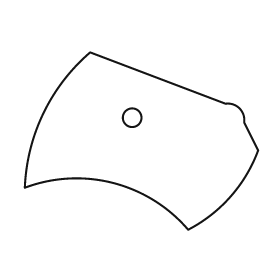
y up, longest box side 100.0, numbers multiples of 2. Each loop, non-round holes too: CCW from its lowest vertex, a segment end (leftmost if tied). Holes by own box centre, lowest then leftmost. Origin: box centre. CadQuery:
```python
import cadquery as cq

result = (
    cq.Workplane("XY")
    .moveTo(20.0, -38.0)
    .threePointArc((38.0, -24.0), (50.0, -4.0))
    .lineTo(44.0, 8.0)
    .threePointArc((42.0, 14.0), (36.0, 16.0))
    .lineTo(-22.0, 38.0)
    .threePointArc((-42.0, 12.0), (-50.0, -20.0))
    .threePointArc((-12.0, -18.0), (20.0, -38.0))
    .close()
    .moveTo(-4.0, 10.0)
    .circle(4.0)
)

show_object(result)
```